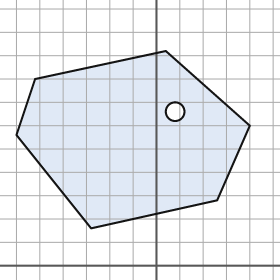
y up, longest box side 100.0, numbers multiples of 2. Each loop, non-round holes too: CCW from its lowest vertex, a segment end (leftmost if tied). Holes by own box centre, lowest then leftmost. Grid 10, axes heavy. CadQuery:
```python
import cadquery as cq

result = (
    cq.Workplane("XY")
    .moveTo(-28.0, 16.0)
    .lineTo(26.0, 28.0)
    .lineTo(40.0, 60.0)
    .lineTo(4.0, 92.0)
    .lineTo(-52.0, 80.0)
    .lineTo(-60.0, 56.0)
    .close()
    .moveTo(8.0, 66.0)
    .circle(4.0)
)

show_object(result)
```